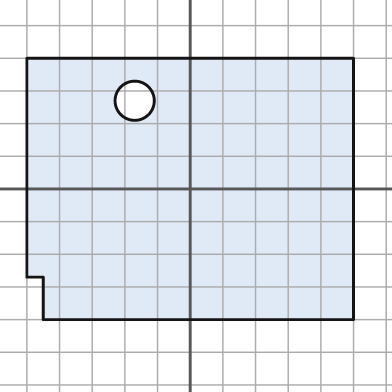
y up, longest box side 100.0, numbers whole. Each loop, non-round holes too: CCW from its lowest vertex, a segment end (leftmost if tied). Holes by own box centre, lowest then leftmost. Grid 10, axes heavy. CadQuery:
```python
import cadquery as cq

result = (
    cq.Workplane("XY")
    .moveTo(-45.0, -40.0)
    .lineTo(50.0, -40.0)
    .lineTo(50.0, 40.0)
    .lineTo(-50.0, 40.0)
    .lineTo(-50.0, -27.0)
    .lineTo(-45.0, -27.0)
    .close()
    .moveTo(-17.0, 27.0)
    .circle(6.0)
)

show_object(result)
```